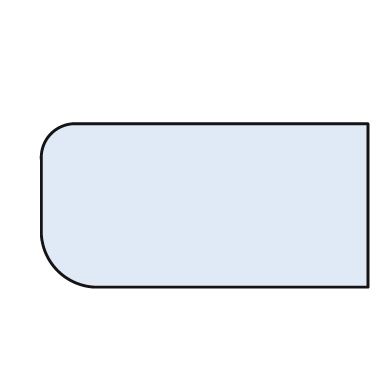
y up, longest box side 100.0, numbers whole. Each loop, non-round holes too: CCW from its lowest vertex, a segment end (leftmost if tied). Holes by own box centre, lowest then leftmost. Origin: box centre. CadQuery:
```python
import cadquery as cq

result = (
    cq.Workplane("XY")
    .moveTo(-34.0, -25.0)
    .lineTo(50.0, -25.0)
    .lineTo(50.0, 25.0)
    .lineTo(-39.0, 25.0)
    .threePointArc((-47.0, 22.0), (-50.0, 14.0))
    .lineTo(-50.0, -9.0)
    .threePointArc((-45.0, -20.0), (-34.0, -25.0))
    .close()
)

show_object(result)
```